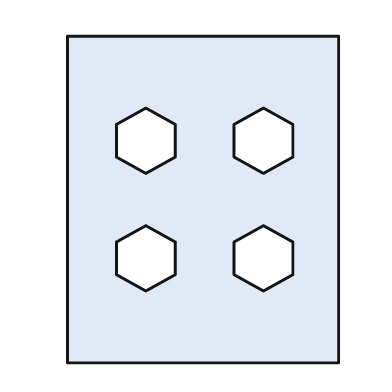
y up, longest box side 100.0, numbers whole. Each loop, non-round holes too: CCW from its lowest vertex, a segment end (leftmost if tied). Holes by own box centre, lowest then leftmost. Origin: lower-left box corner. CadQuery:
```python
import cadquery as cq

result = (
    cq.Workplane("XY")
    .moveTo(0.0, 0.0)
    .lineTo(83.0, 0.0)
    .lineTo(83.0, 100.0)
    .lineTo(0.0, 100.0)
    .close()
    .moveTo(24.0, 22.0)
    .lineTo(33.0, 27.0)
    .lineTo(33.0, 37.0)
    .lineTo(24.0, 42.0)
    .lineTo(15.0, 37.0)
    .lineTo(15.0, 27.0)
    .close()
    .moveTo(60.0, 22.0)
    .lineTo(69.0, 27.0)
    .lineTo(69.0, 37.0)
    .lineTo(60.0, 42.0)
    .lineTo(51.0, 37.0)
    .lineTo(51.0, 27.0)
    .close()
    .moveTo(24.0, 58.0)
    .lineTo(33.0, 63.0)
    .lineTo(33.0, 73.0)
    .lineTo(24.0, 78.0)
    .lineTo(15.0, 73.0)
    .lineTo(15.0, 63.0)
    .close()
    .moveTo(60.0, 58.0)
    .lineTo(69.0, 63.0)
    .lineTo(69.0, 73.0)
    .lineTo(60.0, 78.0)
    .lineTo(51.0, 73.0)
    .lineTo(51.0, 63.0)
    .close()
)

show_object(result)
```